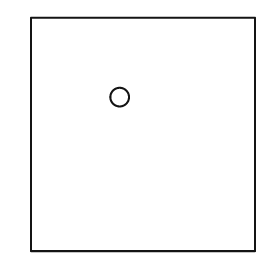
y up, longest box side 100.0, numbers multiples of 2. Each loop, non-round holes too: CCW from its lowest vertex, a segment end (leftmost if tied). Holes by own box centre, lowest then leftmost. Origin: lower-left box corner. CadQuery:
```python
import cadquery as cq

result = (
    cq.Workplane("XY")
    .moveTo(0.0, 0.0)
    .lineTo(96.0, 0.0)
    .lineTo(96.0, 100.0)
    .lineTo(0.0, 100.0)
    .close()
    .moveTo(38.0, 66.0)
    .circle(4.0)
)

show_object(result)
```